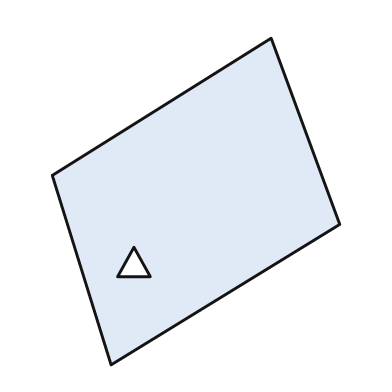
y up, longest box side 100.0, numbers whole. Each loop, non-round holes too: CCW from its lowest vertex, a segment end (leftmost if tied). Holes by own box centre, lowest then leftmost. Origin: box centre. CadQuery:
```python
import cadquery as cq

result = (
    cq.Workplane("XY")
    .moveTo(-26.0, -50.0)
    .lineTo(44.0, -7.0)
    .lineTo(23.0, 50.0)
    .lineTo(-44.0, 8.0)
    .close()
    .moveTo(-24.0, -23.0)
    .lineTo(-14.0, -23.0)
    .lineTo(-19.0, -14.0)
    .close()
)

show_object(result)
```